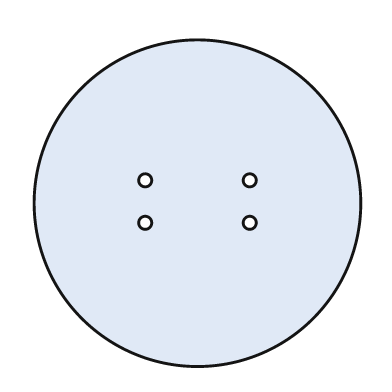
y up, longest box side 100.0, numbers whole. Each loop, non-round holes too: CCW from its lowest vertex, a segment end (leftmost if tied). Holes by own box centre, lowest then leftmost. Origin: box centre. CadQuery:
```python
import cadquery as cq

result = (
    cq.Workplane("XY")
    .moveTo(0.0, 0.0)
    .circle(50.0)
    .moveTo(-16.0, -6.0)
    .circle(2.0)
    .moveTo(16.0, -6.0)
    .circle(2.0)
    .moveTo(-16.0, 7.0)
    .circle(2.0)
    .moveTo(16.0, 7.0)
    .circle(2.0)
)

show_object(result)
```